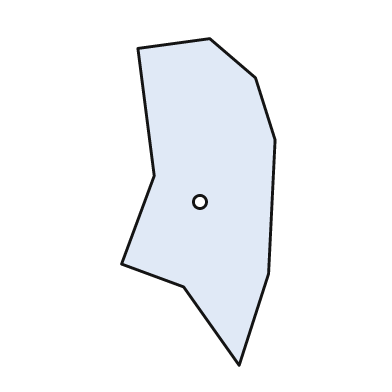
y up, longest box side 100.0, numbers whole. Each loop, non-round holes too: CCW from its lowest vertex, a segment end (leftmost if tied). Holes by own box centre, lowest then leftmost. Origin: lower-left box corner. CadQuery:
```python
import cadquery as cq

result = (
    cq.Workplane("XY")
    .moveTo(36.0, 0.0)
    .lineTo(45.0, 28.0)
    .lineTo(47.0, 69.0)
    .lineTo(41.0, 88.0)
    .lineTo(27.0, 100.0)
    .lineTo(5.0, 97.0)
    .lineTo(10.0, 58.0)
    .lineTo(0.0, 31.0)
    .lineTo(19.0, 24.0)
    .close()
    .moveTo(24.0, 50.0)
    .circle(2.0)
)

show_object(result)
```